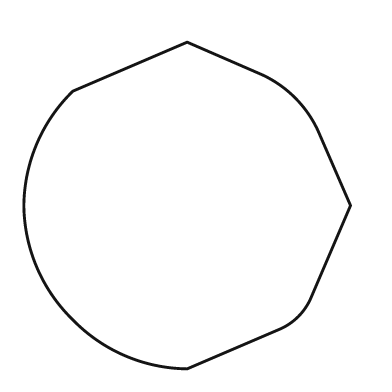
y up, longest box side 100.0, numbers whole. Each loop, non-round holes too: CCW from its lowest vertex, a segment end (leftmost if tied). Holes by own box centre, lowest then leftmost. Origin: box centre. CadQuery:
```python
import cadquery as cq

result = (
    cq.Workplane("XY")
    .moveTo(0.0, -50.0)
    .lineTo(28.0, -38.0)
    .threePointArc((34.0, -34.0), (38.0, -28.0))
    .lineTo(50.0, 0.0)
    .lineTo(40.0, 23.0)
    .threePointArc((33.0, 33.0), (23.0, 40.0))
    .lineTo(0.0, 50.0)
    .lineTo(-35.0, 35.0)
    .threePointArc((-46.0, 19.0), (-50.0, 0.0))
    .threePointArc((-46.0, -19.0), (-35.0, -35.0))
    .threePointArc((-19.0, -46.0), (0.0, -50.0))
    .close()
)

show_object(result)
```